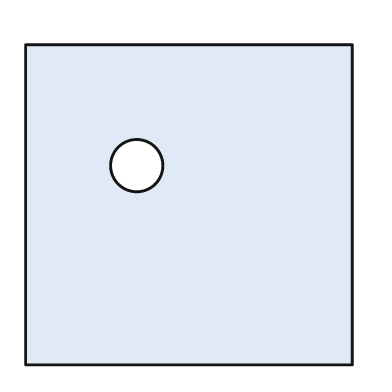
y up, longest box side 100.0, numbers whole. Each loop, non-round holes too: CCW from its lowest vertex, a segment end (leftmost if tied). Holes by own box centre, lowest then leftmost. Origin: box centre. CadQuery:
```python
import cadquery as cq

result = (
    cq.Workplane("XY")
    .moveTo(-50.0, -49.0)
    .lineTo(50.0, -49.0)
    .lineTo(50.0, 49.0)
    .lineTo(-50.0, 49.0)
    .close()
    .moveTo(-16.0, 12.0)
    .circle(8.0)
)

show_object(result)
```